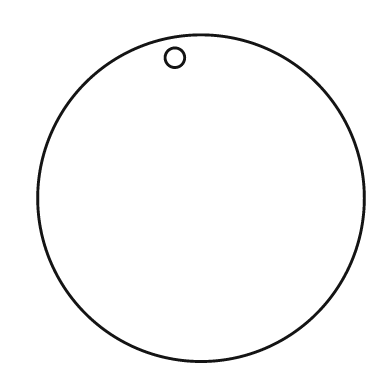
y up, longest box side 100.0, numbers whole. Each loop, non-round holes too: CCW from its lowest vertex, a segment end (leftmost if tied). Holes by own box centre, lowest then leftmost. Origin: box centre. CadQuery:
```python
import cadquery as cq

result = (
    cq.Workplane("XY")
    .moveTo(0.0, 0.0)
    .circle(50.0)
    .moveTo(-8.0, 43.0)
    .circle(3.0)
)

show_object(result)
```